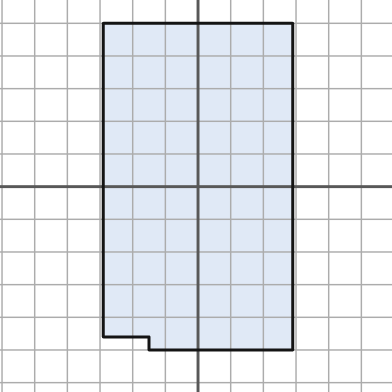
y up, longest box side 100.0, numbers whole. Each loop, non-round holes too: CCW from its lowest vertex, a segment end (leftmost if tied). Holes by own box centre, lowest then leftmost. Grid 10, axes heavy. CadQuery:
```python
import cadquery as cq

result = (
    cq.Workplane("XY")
    .moveTo(-15.0, -50.0)
    .lineTo(29.0, -50.0)
    .lineTo(29.0, 50.0)
    .lineTo(-29.0, 50.0)
    .lineTo(-29.0, -46.0)
    .lineTo(-15.0, -46.0)
    .close()
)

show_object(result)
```